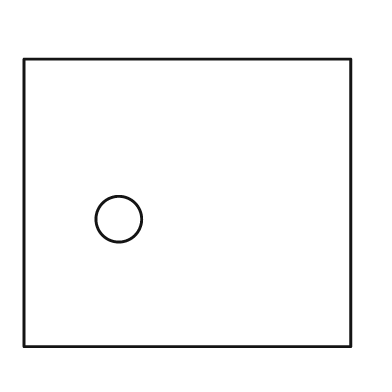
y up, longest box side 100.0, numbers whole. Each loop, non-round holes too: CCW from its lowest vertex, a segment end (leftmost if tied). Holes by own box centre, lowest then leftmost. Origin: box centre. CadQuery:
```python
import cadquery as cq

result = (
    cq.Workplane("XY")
    .moveTo(-50.0, -44.0)
    .lineTo(50.0, -44.0)
    .lineTo(50.0, 44.0)
    .lineTo(-50.0, 44.0)
    .close()
    .moveTo(-21.0, -5.0)
    .circle(7.0)
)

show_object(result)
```